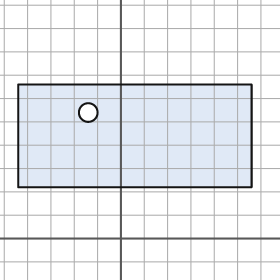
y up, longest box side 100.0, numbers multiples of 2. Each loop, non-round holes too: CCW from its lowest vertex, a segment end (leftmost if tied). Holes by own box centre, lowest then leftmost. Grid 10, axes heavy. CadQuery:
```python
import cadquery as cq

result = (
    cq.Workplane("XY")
    .moveTo(-44.0, 22.0)
    .lineTo(56.0, 22.0)
    .lineTo(56.0, 66.0)
    .lineTo(-44.0, 66.0)
    .close()
    .moveTo(-14.0, 54.0)
    .circle(4.0)
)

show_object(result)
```